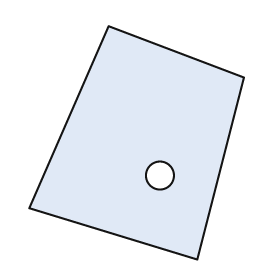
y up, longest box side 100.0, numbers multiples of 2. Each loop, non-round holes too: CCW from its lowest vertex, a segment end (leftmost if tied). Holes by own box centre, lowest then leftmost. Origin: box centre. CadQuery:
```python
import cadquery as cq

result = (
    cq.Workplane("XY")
    .moveTo(26.0, -50.0)
    .lineTo(46.0, 28.0)
    .lineTo(-12.0, 50.0)
    .lineTo(-46.0, -28.0)
    .close()
    .moveTo(10.0, -14.0)
    .circle(6.0)
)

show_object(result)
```